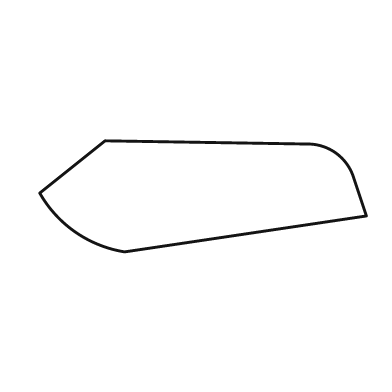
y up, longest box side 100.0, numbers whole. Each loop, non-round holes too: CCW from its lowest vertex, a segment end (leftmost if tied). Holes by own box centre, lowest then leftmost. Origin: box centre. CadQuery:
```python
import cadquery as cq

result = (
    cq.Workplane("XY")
    .moveTo(-24.0, -17.0)
    .lineTo(50.0, -6.0)
    .lineTo(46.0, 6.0)
    .threePointArc((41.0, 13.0), (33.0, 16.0))
    .lineTo(-30.0, 17.0)
    .lineTo(-50.0, 1.0)
    .threePointArc((-39.0, -11.0), (-24.0, -17.0))
    .close()
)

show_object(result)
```